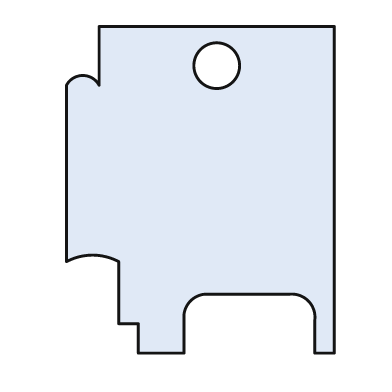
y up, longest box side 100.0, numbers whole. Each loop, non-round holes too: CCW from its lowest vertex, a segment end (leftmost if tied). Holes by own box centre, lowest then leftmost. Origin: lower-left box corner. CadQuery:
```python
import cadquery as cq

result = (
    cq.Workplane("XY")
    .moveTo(22.0, 0.0)
    .lineTo(36.0, 0.0)
    .lineTo(36.0, 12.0)
    .threePointArc((38.0, 16.0), (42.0, 18.0))
    .lineTo(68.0, 18.0)
    .threePointArc((74.0, 16.0), (76.0, 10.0))
    .lineTo(76.0, 0.0)
    .lineTo(82.0, 0.0)
    .lineTo(82.0, 100.0)
    .lineTo(10.0, 100.0)
    .lineTo(10.0, 82.0)
    .threePointArc((5.0, 85.0), (0.0, 82.0))
    .lineTo(0.0, 28.0)
    .threePointArc((8.0, 30.0), (16.0, 28.0))
    .lineTo(16.0, 9.0)
    .lineTo(22.0, 9.0)
    .close()
    .moveTo(46.0, 88.0)
    .circle(7.0)
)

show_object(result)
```